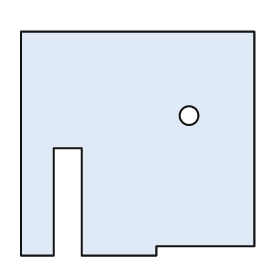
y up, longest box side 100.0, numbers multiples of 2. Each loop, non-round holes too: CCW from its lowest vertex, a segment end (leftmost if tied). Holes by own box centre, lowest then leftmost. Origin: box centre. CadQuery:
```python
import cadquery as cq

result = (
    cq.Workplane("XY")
    .moveTo(-50.0, -48.0)
    .lineTo(-36.0, -48.0)
    .lineTo(-36.0, -2.0)
    .lineTo(-24.0, -2.0)
    .lineTo(-24.0, -48.0)
    .lineTo(8.0, -48.0)
    .lineTo(8.0, -44.0)
    .lineTo(50.0, -44.0)
    .lineTo(50.0, 48.0)
    .lineTo(-50.0, 48.0)
    .close()
    .moveTo(22.0, 12.0)
    .circle(4.0)
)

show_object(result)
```